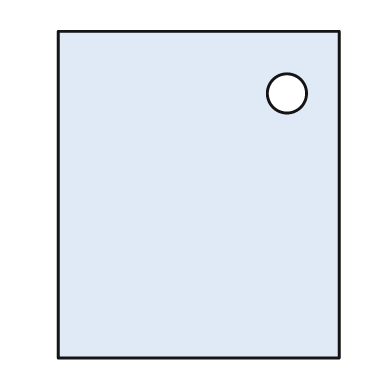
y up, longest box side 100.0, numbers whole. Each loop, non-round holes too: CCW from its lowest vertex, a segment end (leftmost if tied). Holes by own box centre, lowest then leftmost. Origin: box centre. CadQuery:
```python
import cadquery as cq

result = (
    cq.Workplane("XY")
    .moveTo(-43.0, -50.0)
    .lineTo(43.0, -50.0)
    .lineTo(43.0, 50.0)
    .lineTo(-43.0, 50.0)
    .close()
    .moveTo(27.0, 31.0)
    .circle(6.0)
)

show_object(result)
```